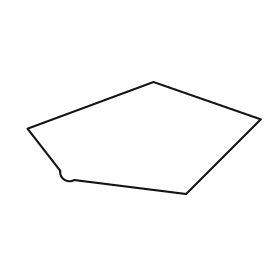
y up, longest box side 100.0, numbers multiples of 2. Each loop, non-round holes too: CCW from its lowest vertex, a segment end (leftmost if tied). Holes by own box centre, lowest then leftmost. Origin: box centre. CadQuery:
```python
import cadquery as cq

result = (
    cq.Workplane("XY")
    .moveTo(18.0, -24.0)
    .lineTo(50.0, 8.0)
    .lineTo(4.0, 24.0)
    .lineTo(-50.0, 4.0)
    .lineTo(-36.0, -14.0)
    .threePointArc((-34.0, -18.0), (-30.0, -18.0))
    .close()
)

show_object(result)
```